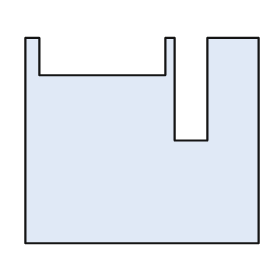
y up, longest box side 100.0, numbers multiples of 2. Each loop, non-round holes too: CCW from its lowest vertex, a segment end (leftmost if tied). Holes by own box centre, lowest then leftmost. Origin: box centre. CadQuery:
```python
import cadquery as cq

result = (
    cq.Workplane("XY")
    .moveTo(-50.0, -44.0)
    .lineTo(50.0, -44.0)
    .lineTo(50.0, 44.0)
    .lineTo(28.0, 44.0)
    .lineTo(28.0, 0.0)
    .lineTo(14.0, 0.0)
    .lineTo(14.0, 44.0)
    .lineTo(10.0, 44.0)
    .lineTo(10.0, 28.0)
    .lineTo(-44.0, 28.0)
    .lineTo(-44.0, 44.0)
    .lineTo(-50.0, 44.0)
    .close()
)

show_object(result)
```